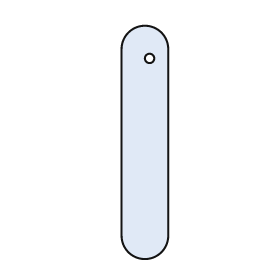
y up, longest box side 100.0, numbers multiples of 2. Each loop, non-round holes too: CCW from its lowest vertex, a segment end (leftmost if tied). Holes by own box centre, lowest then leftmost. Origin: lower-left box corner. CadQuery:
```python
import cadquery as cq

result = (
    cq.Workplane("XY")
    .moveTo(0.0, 10.0)
    .threePointArc((10.0, 0.0), (20.0, 10.0))
    .lineTo(20.0, 90.0)
    .threePointArc((10.0, 100.0), (0.0, 90.0))
    .close()
    .moveTo(12.0, 86.0)
    .circle(2.0)
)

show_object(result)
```